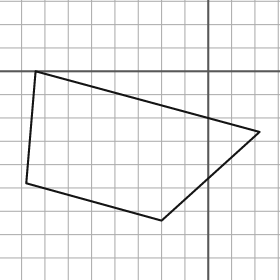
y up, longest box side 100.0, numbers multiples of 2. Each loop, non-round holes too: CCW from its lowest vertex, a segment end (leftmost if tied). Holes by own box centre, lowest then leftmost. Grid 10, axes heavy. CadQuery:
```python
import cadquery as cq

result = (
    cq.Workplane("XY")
    .moveTo(-20.0, -64.0)
    .lineTo(22.0, -26.0)
    .lineTo(-74.0, 0.0)
    .lineTo(-78.0, -48.0)
    .close()
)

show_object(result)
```